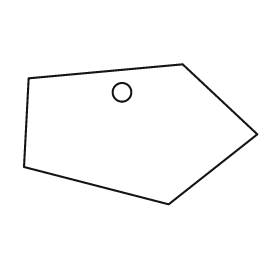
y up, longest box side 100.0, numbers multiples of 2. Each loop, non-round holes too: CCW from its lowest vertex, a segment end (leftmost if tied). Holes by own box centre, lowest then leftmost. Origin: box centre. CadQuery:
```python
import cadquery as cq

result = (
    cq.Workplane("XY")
    .moveTo(12.0, -30.0)
    .lineTo(50.0, 0.0)
    .lineTo(18.0, 30.0)
    .lineTo(-48.0, 24.0)
    .lineTo(-50.0, -14.0)
    .close()
    .moveTo(-8.0, 18.0)
    .circle(4.0)
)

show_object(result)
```